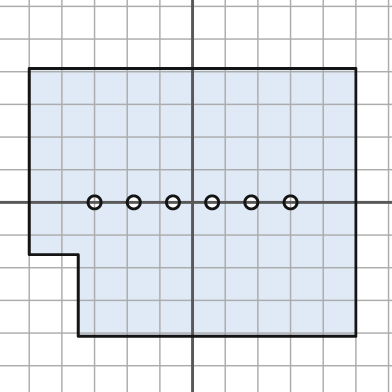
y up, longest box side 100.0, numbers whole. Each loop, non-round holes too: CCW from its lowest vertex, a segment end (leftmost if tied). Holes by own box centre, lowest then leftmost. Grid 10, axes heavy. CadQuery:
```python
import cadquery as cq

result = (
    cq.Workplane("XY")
    .moveTo(-35.0, -41.0)
    .lineTo(50.0, -41.0)
    .lineTo(50.0, 41.0)
    .lineTo(-50.0, 41.0)
    .lineTo(-50.0, -16.0)
    .lineTo(-35.0, -16.0)
    .close()
    .moveTo(-30.0, 0.0)
    .circle(2.0)
    .moveTo(-18.0, 0.0)
    .circle(2.0)
    .moveTo(-6.0, 0.0)
    .circle(2.0)
    .moveTo(6.0, 0.0)
    .circle(2.0)
    .moveTo(18.0, 0.0)
    .circle(2.0)
    .moveTo(30.0, 0.0)
    .circle(2.0)
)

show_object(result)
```